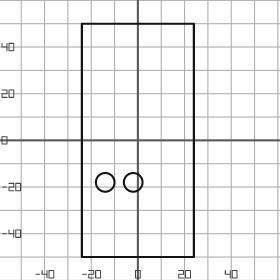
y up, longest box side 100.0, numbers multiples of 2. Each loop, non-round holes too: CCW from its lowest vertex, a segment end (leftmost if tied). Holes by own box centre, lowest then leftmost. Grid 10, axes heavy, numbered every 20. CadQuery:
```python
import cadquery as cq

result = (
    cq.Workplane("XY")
    .moveTo(-24.0, -50.0)
    .lineTo(24.0, -50.0)
    .lineTo(24.0, 50.0)
    .lineTo(-24.0, 50.0)
    .close()
    .moveTo(-14.0, -18.0)
    .circle(4.0)
    .moveTo(-2.0, -18.0)
    .circle(4.0)
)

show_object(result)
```